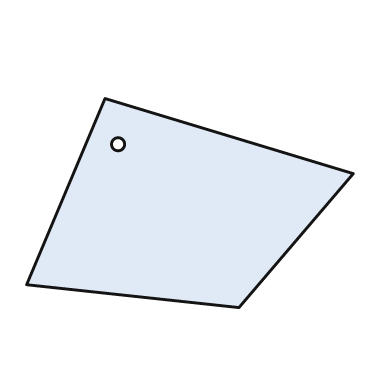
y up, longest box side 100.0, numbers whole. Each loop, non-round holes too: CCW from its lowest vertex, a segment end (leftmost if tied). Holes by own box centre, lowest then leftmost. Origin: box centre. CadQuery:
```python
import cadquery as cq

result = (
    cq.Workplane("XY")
    .moveTo(15.0, -32.0)
    .lineTo(50.0, 9.0)
    .lineTo(-26.0, 32.0)
    .lineTo(-50.0, -25.0)
    .close()
    .moveTo(-22.0, 18.0)
    .circle(2.0)
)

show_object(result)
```